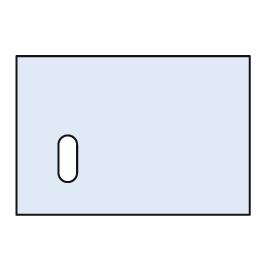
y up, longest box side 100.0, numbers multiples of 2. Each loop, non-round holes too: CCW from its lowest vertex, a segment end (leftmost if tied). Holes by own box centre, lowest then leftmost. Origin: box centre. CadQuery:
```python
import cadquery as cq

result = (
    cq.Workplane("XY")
    .moveTo(-50.0, -34.0)
    .lineTo(50.0, -34.0)
    .lineTo(50.0, 34.0)
    .lineTo(-50.0, 34.0)
    .close()
    .moveTo(-32.0, -16.0)
    .threePointArc((-28.0, -20.0), (-24.0, -16.0))
    .lineTo(-24.0, -4.0)
    .threePointArc((-28.0, 0.0), (-32.0, -4.0))
    .close()
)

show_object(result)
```